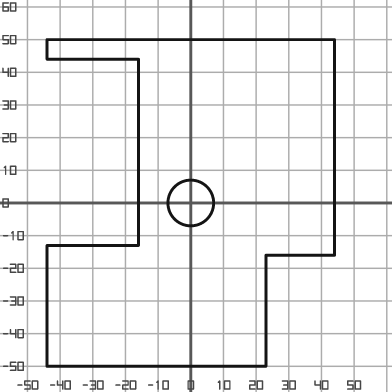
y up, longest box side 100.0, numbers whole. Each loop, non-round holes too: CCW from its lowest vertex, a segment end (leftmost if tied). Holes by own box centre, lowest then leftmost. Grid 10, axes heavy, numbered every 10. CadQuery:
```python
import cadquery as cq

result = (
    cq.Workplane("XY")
    .moveTo(-44.0, -50.0)
    .lineTo(23.0, -50.0)
    .lineTo(23.0, -16.0)
    .lineTo(44.0, -16.0)
    .lineTo(44.0, 50.0)
    .lineTo(-44.0, 50.0)
    .lineTo(-44.0, 44.0)
    .lineTo(-16.0, 44.0)
    .lineTo(-16.0, -13.0)
    .lineTo(-44.0, -13.0)
    .close()
    .moveTo(0.0, 0.0)
    .circle(7.0)
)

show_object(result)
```